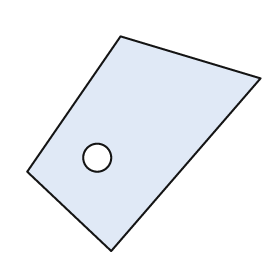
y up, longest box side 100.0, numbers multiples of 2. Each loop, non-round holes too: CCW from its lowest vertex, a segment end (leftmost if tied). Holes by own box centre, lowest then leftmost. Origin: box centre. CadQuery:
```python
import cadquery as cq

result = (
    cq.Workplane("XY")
    .moveTo(-14.0, -46.0)
    .lineTo(50.0, 28.0)
    .lineTo(-10.0, 46.0)
    .lineTo(-50.0, -12.0)
    .close()
    .moveTo(-20.0, -6.0)
    .circle(6.0)
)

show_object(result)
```